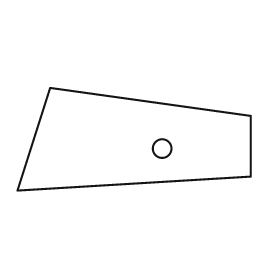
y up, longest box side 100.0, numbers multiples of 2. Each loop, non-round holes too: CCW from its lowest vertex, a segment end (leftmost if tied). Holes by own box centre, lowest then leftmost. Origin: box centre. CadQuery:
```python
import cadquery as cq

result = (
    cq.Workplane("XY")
    .moveTo(-50.0, -22.0)
    .lineTo(50.0, -16.0)
    .lineTo(50.0, 10.0)
    .lineTo(-36.0, 22.0)
    .close()
    .moveTo(12.0, -4.0)
    .circle(4.0)
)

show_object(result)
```